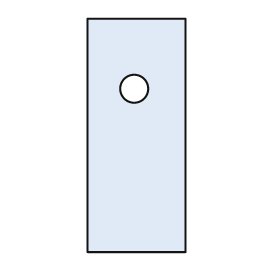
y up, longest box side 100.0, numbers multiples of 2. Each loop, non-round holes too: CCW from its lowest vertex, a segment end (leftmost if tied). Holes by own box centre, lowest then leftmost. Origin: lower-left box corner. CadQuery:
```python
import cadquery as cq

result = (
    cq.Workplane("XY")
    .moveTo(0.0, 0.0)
    .lineTo(42.0, 0.0)
    .lineTo(42.0, 100.0)
    .lineTo(0.0, 100.0)
    .close()
    .moveTo(20.0, 70.0)
    .circle(6.0)
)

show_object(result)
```